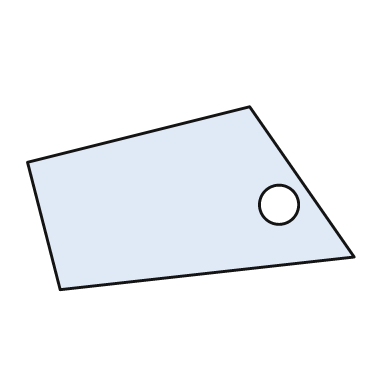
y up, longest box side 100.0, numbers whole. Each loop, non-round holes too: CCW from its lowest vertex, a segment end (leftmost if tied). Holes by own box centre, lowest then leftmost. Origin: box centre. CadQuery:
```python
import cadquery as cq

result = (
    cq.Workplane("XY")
    .moveTo(-40.0, -28.0)
    .lineTo(50.0, -18.0)
    .lineTo(18.0, 28.0)
    .lineTo(-50.0, 11.0)
    .close()
    .moveTo(27.0, -2.0)
    .circle(6.0)
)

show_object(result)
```